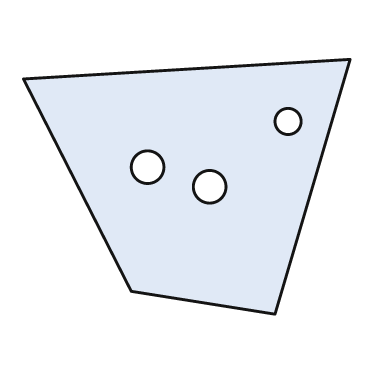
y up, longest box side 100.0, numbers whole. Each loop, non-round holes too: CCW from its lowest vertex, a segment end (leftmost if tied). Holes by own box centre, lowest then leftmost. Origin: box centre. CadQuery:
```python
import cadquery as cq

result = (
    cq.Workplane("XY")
    .moveTo(27.0, -39.0)
    .lineTo(50.0, 39.0)
    .lineTo(-50.0, 33.0)
    .lineTo(-17.0, -32.0)
    .close()
    .moveTo(7.0, 0.0)
    .circle(5.0)
    .moveTo(-12.0, 6.0)
    .circle(5.0)
    .moveTo(31.0, 20.0)
    .circle(4.0)
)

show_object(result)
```